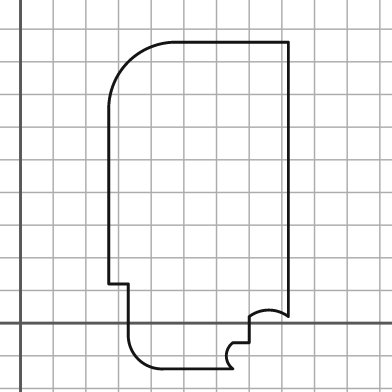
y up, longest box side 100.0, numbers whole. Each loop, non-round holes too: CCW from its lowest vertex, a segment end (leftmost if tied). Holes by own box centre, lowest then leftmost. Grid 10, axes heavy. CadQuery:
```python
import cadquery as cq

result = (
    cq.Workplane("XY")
    .moveTo(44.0, -14.0)
    .lineTo(65.0, -14.0)
    .threePointArc((63.0, -10.0), (65.0, -6.0))
    .lineTo(70.0, -6.0)
    .lineTo(70.0, 2.0)
    .threePointArc((76.0, 4.0), (82.0, 2.0))
    .lineTo(82.0, 86.0)
    .lineTo(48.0, 86.0)
    .threePointArc((33.0, 80.0), (27.0, 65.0))
    .lineTo(27.0, 12.0)
    .lineTo(33.0, 12.0)
    .lineTo(33.0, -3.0)
    .threePointArc((36.0, -11.0), (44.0, -14.0))
    .close()
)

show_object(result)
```